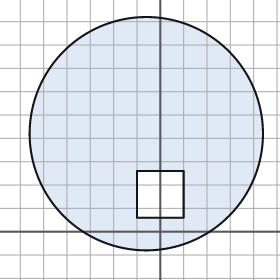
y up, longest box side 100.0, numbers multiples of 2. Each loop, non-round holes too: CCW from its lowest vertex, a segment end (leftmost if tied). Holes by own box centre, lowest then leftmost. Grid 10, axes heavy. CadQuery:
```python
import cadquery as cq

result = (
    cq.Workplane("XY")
    .moveTo(-6.0, 42.0)
    .circle(50.0)
    .moveTo(-10.0, 6.0)
    .lineTo(10.0, 6.0)
    .lineTo(10.0, 26.0)
    .lineTo(-10.0, 26.0)
    .close()
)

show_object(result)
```